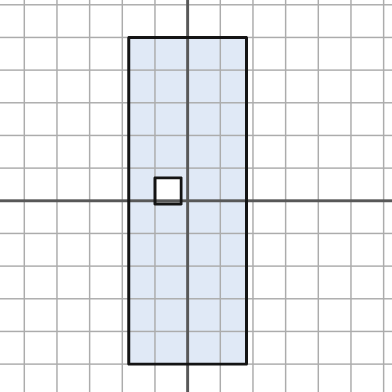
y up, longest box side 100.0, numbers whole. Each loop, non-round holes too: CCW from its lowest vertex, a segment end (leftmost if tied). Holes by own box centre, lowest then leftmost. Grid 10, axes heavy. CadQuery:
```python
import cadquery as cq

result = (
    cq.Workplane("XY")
    .moveTo(-18.0, -50.0)
    .lineTo(18.0, -50.0)
    .lineTo(18.0, 50.0)
    .lineTo(-18.0, 50.0)
    .close()
    .moveTo(-10.0, -1.0)
    .lineTo(-2.0, -1.0)
    .lineTo(-2.0, 7.0)
    .lineTo(-10.0, 7.0)
    .close()
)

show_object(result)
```